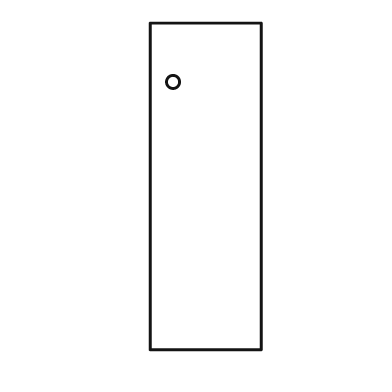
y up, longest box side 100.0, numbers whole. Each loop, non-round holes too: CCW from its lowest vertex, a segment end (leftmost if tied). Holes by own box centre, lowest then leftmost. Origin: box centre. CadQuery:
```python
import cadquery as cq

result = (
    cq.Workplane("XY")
    .moveTo(-17.0, -50.0)
    .lineTo(17.0, -50.0)
    .lineTo(17.0, 50.0)
    .lineTo(-17.0, 50.0)
    .close()
    .moveTo(-10.0, 32.0)
    .circle(2.0)
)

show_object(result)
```